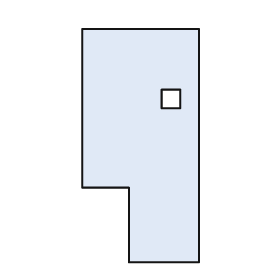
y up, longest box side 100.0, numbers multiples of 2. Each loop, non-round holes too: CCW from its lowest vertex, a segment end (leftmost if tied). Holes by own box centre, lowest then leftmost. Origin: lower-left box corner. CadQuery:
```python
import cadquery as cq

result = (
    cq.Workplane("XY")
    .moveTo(20.0, 0.0)
    .lineTo(50.0, 0.0)
    .lineTo(50.0, 100.0)
    .lineTo(0.0, 100.0)
    .lineTo(0.0, 32.0)
    .lineTo(20.0, 32.0)
    .close()
    .moveTo(34.0, 66.0)
    .lineTo(42.0, 66.0)
    .lineTo(42.0, 74.0)
    .lineTo(34.0, 74.0)
    .close()
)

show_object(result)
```